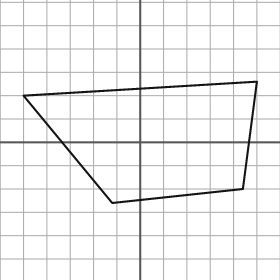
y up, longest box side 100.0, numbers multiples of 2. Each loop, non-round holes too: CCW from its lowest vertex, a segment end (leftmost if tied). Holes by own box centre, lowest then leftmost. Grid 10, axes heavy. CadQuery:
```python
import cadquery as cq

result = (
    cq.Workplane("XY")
    .moveTo(-12.0, -26.0)
    .lineTo(44.0, -20.0)
    .lineTo(50.0, 26.0)
    .lineTo(-50.0, 20.0)
    .close()
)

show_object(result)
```